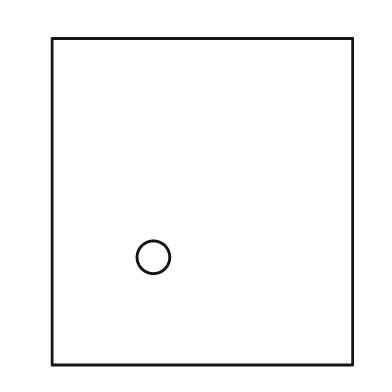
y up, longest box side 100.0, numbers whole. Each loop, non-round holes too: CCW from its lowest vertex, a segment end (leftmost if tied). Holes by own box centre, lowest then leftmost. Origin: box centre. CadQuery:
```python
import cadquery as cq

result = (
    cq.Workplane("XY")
    .moveTo(-46.0, -50.0)
    .lineTo(46.0, -50.0)
    .lineTo(46.0, 50.0)
    .lineTo(-46.0, 50.0)
    .close()
    .moveTo(-15.0, -17.0)
    .circle(5.0)
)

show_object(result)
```